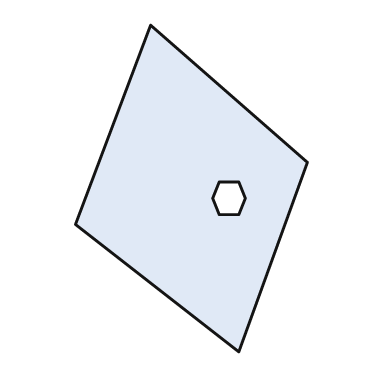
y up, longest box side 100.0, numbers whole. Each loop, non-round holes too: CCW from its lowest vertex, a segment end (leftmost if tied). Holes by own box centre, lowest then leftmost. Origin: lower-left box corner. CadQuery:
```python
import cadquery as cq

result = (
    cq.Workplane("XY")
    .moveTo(50.0, 0.0)
    .lineTo(71.0, 58.0)
    .lineTo(23.0, 100.0)
    .lineTo(0.0, 39.0)
    .close()
    .moveTo(44.0, 42.0)
    .lineTo(50.0, 42.0)
    .lineTo(52.0, 47.0)
    .lineTo(50.0, 52.0)
    .lineTo(44.0, 52.0)
    .lineTo(42.0, 47.0)
    .close()
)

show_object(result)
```